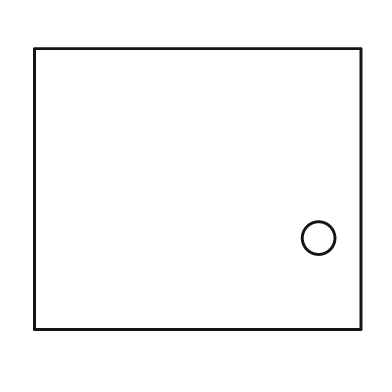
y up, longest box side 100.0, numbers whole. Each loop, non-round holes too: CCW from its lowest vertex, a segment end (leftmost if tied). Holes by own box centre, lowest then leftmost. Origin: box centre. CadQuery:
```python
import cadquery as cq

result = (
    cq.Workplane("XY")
    .moveTo(-50.0, -43.0)
    .lineTo(50.0, -43.0)
    .lineTo(50.0, 43.0)
    .lineTo(-50.0, 43.0)
    .close()
    .moveTo(37.0, -15.0)
    .circle(5.0)
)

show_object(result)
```